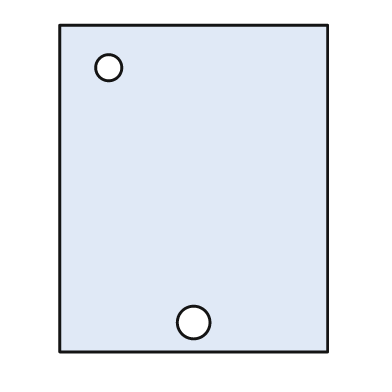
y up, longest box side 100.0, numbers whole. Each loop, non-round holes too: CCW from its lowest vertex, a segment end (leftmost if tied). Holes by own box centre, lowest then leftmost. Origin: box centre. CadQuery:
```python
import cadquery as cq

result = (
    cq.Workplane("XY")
    .moveTo(-41.0, -50.0)
    .lineTo(41.0, -50.0)
    .lineTo(41.0, 50.0)
    .lineTo(-41.0, 50.0)
    .close()
    .moveTo(0.0, -41.0)
    .circle(5.0)
    .moveTo(-26.0, 37.0)
    .circle(4.0)
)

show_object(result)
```